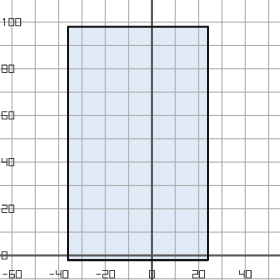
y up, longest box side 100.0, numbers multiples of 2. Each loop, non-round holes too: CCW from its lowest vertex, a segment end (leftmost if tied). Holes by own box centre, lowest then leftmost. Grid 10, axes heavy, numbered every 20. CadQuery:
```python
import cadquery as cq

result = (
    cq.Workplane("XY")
    .moveTo(-36.0, -2.0)
    .lineTo(24.0, -2.0)
    .lineTo(24.0, 98.0)
    .lineTo(-36.0, 98.0)
    .close()
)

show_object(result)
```